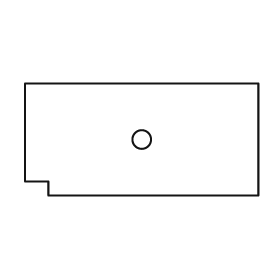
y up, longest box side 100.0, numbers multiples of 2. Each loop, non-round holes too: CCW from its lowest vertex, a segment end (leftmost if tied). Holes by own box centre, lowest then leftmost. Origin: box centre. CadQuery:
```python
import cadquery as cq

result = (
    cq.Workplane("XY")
    .moveTo(-40.0, -24.0)
    .lineTo(50.0, -24.0)
    .lineTo(50.0, 24.0)
    .lineTo(-50.0, 24.0)
    .lineTo(-50.0, -18.0)
    .lineTo(-40.0, -18.0)
    .close()
    .moveTo(0.0, 0.0)
    .circle(4.0)
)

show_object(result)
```